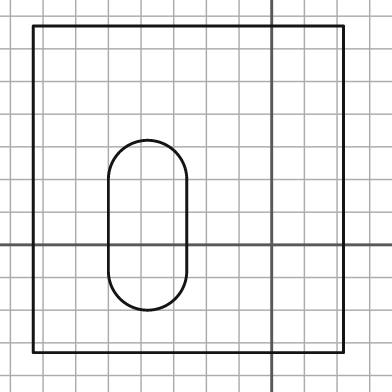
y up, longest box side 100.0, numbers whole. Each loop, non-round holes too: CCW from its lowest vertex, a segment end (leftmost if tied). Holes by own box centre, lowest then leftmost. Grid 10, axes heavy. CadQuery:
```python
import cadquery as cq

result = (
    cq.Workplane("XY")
    .moveTo(-73.0, -33.0)
    .lineTo(22.0, -33.0)
    .lineTo(22.0, 67.0)
    .lineTo(-73.0, 67.0)
    .close()
    .moveTo(-50.0, -8.0)
    .threePointArc((-38.0, -20.0), (-26.0, -8.0))
    .lineTo(-26.0, 20.0)
    .threePointArc((-38.0, 32.0), (-50.0, 20.0))
    .close()
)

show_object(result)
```